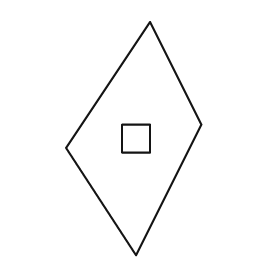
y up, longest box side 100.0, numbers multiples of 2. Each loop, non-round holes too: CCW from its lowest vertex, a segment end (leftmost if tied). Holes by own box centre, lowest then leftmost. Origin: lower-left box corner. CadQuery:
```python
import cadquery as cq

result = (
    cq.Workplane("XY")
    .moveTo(30.0, 0.0)
    .lineTo(58.0, 56.0)
    .lineTo(36.0, 100.0)
    .lineTo(0.0, 46.0)
    .close()
    .moveTo(24.0, 44.0)
    .lineTo(36.0, 44.0)
    .lineTo(36.0, 56.0)
    .lineTo(24.0, 56.0)
    .close()
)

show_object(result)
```